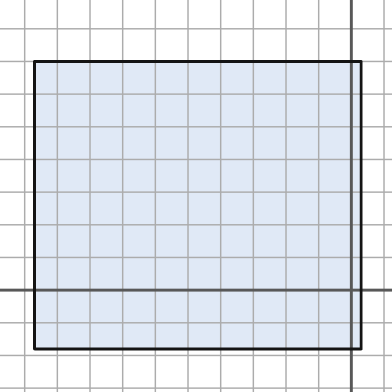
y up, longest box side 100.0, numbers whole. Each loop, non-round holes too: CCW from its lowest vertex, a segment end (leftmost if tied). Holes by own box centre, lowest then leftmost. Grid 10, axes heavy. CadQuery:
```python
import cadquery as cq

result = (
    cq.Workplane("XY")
    .moveTo(-97.0, -18.0)
    .lineTo(3.0, -18.0)
    .lineTo(3.0, 70.0)
    .lineTo(-97.0, 70.0)
    .close()
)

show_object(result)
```